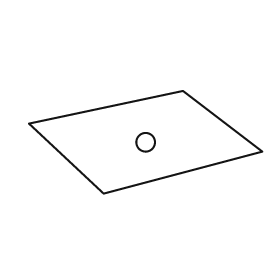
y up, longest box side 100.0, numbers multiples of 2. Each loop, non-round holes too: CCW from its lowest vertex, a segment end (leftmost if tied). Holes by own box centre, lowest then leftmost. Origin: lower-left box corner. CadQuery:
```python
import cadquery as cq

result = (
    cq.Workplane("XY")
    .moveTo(32.0, 0.0)
    .lineTo(100.0, 18.0)
    .lineTo(66.0, 44.0)
    .lineTo(0.0, 30.0)
    .close()
    .moveTo(50.0, 22.0)
    .circle(4.0)
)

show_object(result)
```